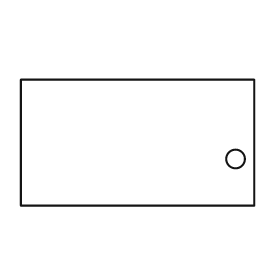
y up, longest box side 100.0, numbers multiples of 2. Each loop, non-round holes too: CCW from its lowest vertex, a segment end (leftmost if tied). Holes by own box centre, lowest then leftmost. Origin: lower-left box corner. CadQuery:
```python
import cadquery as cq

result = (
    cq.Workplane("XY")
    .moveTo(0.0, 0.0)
    .lineTo(100.0, 0.0)
    .lineTo(100.0, 54.0)
    .lineTo(0.0, 54.0)
    .close()
    .moveTo(92.0, 20.0)
    .circle(4.0)
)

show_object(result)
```